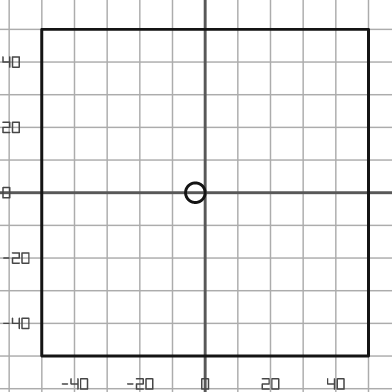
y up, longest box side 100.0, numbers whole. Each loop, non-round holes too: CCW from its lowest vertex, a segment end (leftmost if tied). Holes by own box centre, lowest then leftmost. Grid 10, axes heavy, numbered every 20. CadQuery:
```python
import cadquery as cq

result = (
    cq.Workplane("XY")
    .moveTo(-50.0, -50.0)
    .lineTo(50.0, -50.0)
    .lineTo(50.0, 50.0)
    .lineTo(-50.0, 50.0)
    .close()
    .moveTo(-3.0, 0.0)
    .circle(3.0)
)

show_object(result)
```